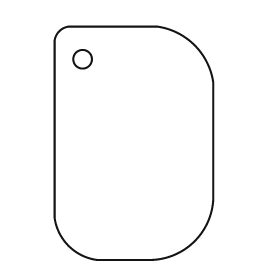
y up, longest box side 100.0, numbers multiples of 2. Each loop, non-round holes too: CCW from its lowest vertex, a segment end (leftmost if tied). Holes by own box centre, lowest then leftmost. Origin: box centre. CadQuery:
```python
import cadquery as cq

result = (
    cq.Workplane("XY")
    .moveTo(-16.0, -50.0)
    .lineTo(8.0, -50.0)
    .threePointArc((26.0, -42.0), (34.0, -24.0))
    .lineTo(34.0, 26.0)
    .threePointArc((26.0, 42.0), (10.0, 50.0))
    .lineTo(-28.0, 50.0)
    .threePointArc((-32.0, 48.0), (-34.0, 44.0))
    .lineTo(-34.0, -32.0)
    .threePointArc((-28.0, -44.0), (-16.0, -50.0))
    .close()
    .moveTo(-22.0, 36.0)
    .circle(4.0)
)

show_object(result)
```